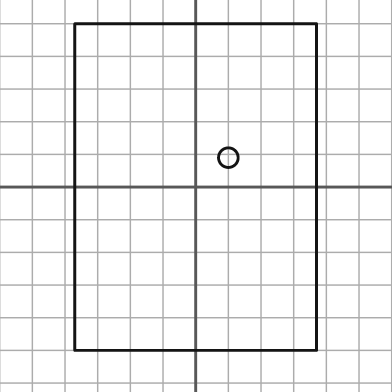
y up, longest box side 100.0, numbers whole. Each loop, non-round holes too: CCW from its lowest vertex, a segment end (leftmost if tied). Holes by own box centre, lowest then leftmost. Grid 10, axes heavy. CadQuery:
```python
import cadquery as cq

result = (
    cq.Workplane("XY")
    .moveTo(-37.0, -50.0)
    .lineTo(37.0, -50.0)
    .lineTo(37.0, 50.0)
    .lineTo(-37.0, 50.0)
    .close()
    .moveTo(10.0, 9.0)
    .circle(3.0)
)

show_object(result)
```